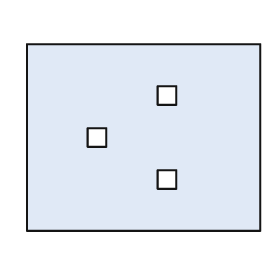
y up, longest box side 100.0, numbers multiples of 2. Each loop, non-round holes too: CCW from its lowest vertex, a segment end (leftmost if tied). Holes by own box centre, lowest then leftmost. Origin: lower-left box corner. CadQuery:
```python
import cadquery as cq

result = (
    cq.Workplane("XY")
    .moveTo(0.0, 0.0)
    .lineTo(100.0, 0.0)
    .lineTo(100.0, 80.0)
    .lineTo(0.0, 80.0)
    .close()
    .moveTo(56.0, 18.0)
    .lineTo(64.0, 18.0)
    .lineTo(64.0, 26.0)
    .lineTo(56.0, 26.0)
    .close()
    .moveTo(26.0, 36.0)
    .lineTo(34.0, 36.0)
    .lineTo(34.0, 44.0)
    .lineTo(26.0, 44.0)
    .close()
    .moveTo(56.0, 54.0)
    .lineTo(64.0, 54.0)
    .lineTo(64.0, 62.0)
    .lineTo(56.0, 62.0)
    .close()
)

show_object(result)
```